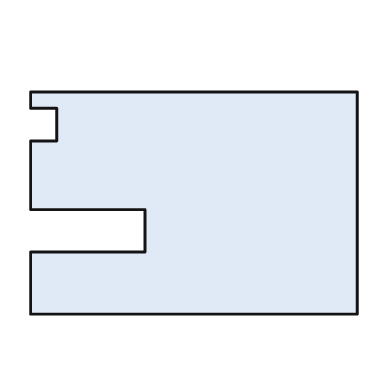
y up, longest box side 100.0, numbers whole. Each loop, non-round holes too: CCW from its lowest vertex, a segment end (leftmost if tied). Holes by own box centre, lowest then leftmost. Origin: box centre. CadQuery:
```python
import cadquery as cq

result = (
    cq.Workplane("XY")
    .moveTo(-50.0, -34.0)
    .lineTo(50.0, -34.0)
    .lineTo(50.0, 34.0)
    .lineTo(-50.0, 34.0)
    .lineTo(-50.0, 29.0)
    .lineTo(-42.0, 29.0)
    .lineTo(-42.0, 19.0)
    .lineTo(-50.0, 19.0)
    .lineTo(-50.0, -2.0)
    .lineTo(-15.0, -2.0)
    .lineTo(-15.0, -15.0)
    .lineTo(-50.0, -15.0)
    .close()
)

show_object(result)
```